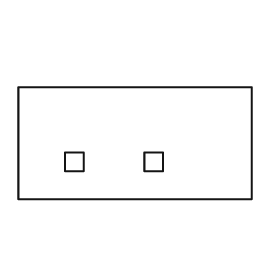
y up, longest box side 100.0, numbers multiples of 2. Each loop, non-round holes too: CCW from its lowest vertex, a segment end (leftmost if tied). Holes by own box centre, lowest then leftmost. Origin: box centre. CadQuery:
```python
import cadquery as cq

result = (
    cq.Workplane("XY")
    .moveTo(-50.0, -24.0)
    .lineTo(50.0, -24.0)
    .lineTo(50.0, 24.0)
    .lineTo(-50.0, 24.0)
    .close()
    .moveTo(-30.0, -12.0)
    .lineTo(-22.0, -12.0)
    .lineTo(-22.0, -4.0)
    .lineTo(-30.0, -4.0)
    .close()
    .moveTo(4.0, -12.0)
    .lineTo(12.0, -12.0)
    .lineTo(12.0, -4.0)
    .lineTo(4.0, -4.0)
    .close()
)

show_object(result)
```